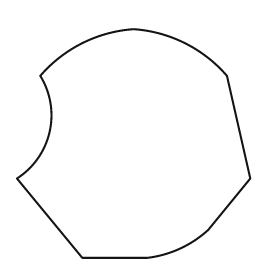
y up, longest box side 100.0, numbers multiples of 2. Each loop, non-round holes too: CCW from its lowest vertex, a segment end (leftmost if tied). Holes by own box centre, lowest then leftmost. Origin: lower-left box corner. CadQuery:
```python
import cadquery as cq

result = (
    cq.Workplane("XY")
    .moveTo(28.0, 0.0)
    .lineTo(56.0, 0.0)
    .threePointArc((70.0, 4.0), (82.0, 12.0))
    .lineTo(100.0, 34.0)
    .lineTo(90.0, 78.0)
    .threePointArc((72.0, 92.0), (50.0, 98.0))
    .threePointArc((28.0, 92.0), (10.0, 78.0))
    .threePointArc((14.0, 54.0), (0.0, 34.0))
    .close()
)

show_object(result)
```